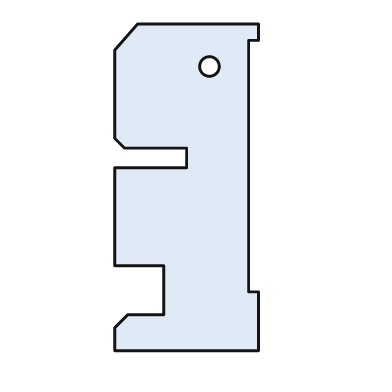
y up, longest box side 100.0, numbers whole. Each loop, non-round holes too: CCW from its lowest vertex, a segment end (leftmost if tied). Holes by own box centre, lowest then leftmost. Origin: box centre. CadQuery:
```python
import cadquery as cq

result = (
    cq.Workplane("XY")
    .moveTo(-22.0, -50.0)
    .lineTo(22.0, -50.0)
    .lineTo(22.0, -32.0)
    .lineTo(19.0, -32.0)
    .lineTo(19.0, 45.0)
    .lineTo(22.0, 45.0)
    .lineTo(22.0, 50.0)
    .lineTo(-15.0, 50.0)
    .lineTo(-22.0, 42.0)
    .lineTo(-22.0, 15.0)
    .lineTo(-19.0, 12.0)
    .lineTo(0.0, 12.0)
    .lineTo(0.0, 6.0)
    .lineTo(-22.0, 6.0)
    .lineTo(-22.0, -24.0)
    .lineTo(-7.0, -24.0)
    .lineTo(-7.0, -39.0)
    .lineTo(-18.0, -39.0)
    .lineTo(-22.0, -43.0)
    .close()
    .moveTo(7.0, 37.0)
    .circle(3.0)
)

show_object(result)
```